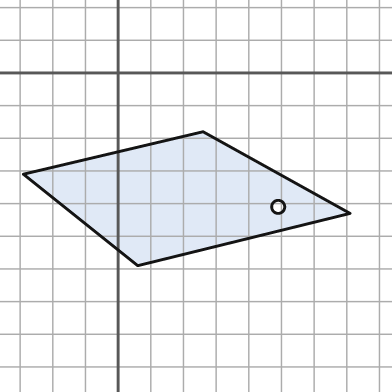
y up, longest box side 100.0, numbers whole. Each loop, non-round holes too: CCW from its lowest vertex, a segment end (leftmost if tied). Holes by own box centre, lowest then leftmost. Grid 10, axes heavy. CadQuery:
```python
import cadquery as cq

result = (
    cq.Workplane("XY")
    .moveTo(6.0, -59.0)
    .lineTo(71.0, -43.0)
    .lineTo(26.0, -18.0)
    .lineTo(-29.0, -31.0)
    .close()
    .moveTo(49.0, -41.0)
    .circle(2.0)
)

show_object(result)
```